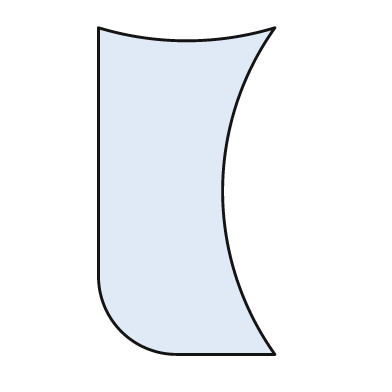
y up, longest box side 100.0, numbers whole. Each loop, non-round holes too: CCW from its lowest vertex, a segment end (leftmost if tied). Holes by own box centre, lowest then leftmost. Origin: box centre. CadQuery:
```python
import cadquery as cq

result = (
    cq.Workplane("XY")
    .moveTo(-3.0, -50.0)
    .lineTo(27.0, -50.0)
    .threePointArc((11.0, 0.0), (27.0, 50.0))
    .threePointArc((0.0, 46.0), (-27.0, 50.0))
    .lineTo(-27.0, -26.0)
    .threePointArc((-20.0, -43.0), (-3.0, -50.0))
    .close()
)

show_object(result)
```